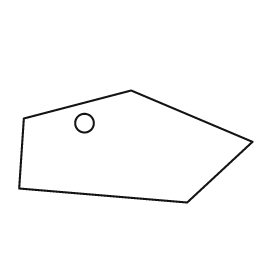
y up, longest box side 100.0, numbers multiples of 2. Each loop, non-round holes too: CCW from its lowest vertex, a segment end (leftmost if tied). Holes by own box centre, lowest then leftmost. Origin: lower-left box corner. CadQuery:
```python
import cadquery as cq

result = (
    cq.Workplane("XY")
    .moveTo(72.0, 0.0)
    .lineTo(100.0, 26.0)
    .lineTo(48.0, 48.0)
    .lineTo(2.0, 36.0)
    .lineTo(0.0, 6.0)
    .close()
    .moveTo(28.0, 34.0)
    .circle(4.0)
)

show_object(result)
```